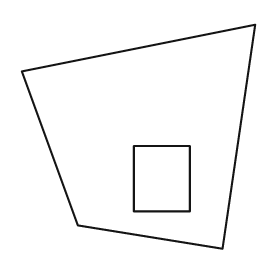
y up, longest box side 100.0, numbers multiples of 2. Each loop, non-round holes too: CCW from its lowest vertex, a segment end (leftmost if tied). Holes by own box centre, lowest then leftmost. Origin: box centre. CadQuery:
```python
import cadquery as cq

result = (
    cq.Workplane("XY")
    .moveTo(36.0, -48.0)
    .lineTo(50.0, 48.0)
    .lineTo(-50.0, 28.0)
    .lineTo(-26.0, -38.0)
    .close()
    .moveTo(-2.0, -32.0)
    .lineTo(22.0, -32.0)
    .lineTo(22.0, -4.0)
    .lineTo(-2.0, -4.0)
    .close()
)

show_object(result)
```